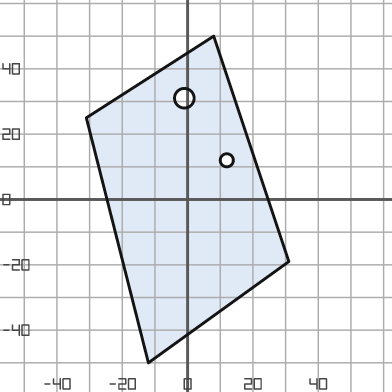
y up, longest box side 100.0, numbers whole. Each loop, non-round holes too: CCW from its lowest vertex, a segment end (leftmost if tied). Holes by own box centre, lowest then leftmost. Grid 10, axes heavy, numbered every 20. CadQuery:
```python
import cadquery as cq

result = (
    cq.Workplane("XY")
    .moveTo(-12.0, -50.0)
    .lineTo(31.0, -19.0)
    .lineTo(8.0, 50.0)
    .lineTo(-31.0, 25.0)
    .close()
    .moveTo(12.0, 12.0)
    .circle(2.0)
    .moveTo(-1.0, 31.0)
    .circle(3.0)
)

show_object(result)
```